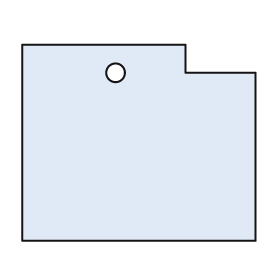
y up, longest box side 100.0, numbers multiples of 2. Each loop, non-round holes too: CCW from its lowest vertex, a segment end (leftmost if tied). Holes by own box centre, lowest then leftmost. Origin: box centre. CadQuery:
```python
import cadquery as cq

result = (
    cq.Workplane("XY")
    .moveTo(-50.0, -42.0)
    .lineTo(50.0, -42.0)
    .lineTo(50.0, 30.0)
    .lineTo(20.0, 30.0)
    .lineTo(20.0, 42.0)
    .lineTo(-50.0, 42.0)
    .close()
    .moveTo(-10.0, 30.0)
    .circle(4.0)
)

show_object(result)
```